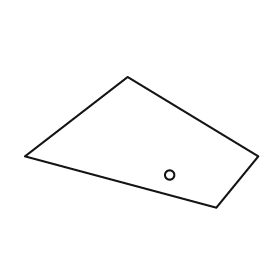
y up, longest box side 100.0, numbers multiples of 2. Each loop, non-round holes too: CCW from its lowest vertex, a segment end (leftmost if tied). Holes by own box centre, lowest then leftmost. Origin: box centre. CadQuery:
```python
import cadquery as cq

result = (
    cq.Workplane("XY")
    .moveTo(32.0, -28.0)
    .lineTo(50.0, -6.0)
    .lineTo(-6.0, 28.0)
    .lineTo(-50.0, -6.0)
    .close()
    .moveTo(12.0, -14.0)
    .circle(2.0)
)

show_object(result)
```